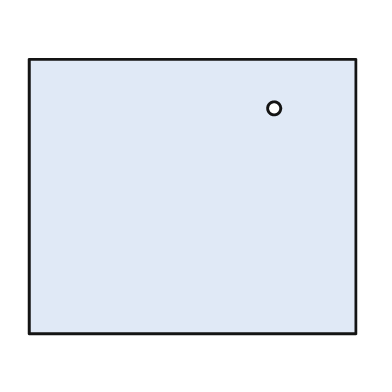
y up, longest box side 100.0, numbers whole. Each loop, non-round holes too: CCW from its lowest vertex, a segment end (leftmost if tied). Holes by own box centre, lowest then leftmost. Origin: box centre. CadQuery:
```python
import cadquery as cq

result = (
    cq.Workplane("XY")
    .moveTo(-50.0, -42.0)
    .lineTo(50.0, -42.0)
    .lineTo(50.0, 42.0)
    .lineTo(-50.0, 42.0)
    .close()
    .moveTo(25.0, 27.0)
    .circle(2.0)
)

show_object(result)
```